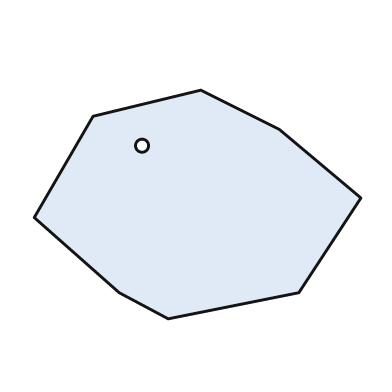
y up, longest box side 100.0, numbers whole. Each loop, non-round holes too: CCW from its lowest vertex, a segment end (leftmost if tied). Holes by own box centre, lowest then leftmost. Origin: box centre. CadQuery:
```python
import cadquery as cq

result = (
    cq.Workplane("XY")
    .moveTo(-9.0, -35.0)
    .lineTo(31.0, -27.0)
    .lineTo(50.0, 2.0)
    .lineTo(25.0, 23.0)
    .lineTo(1.0, 35.0)
    .lineTo(-32.0, 27.0)
    .lineTo(-50.0, -4.0)
    .lineTo(-24.0, -27.0)
    .close()
    .moveTo(-17.0, 18.0)
    .circle(2.0)
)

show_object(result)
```